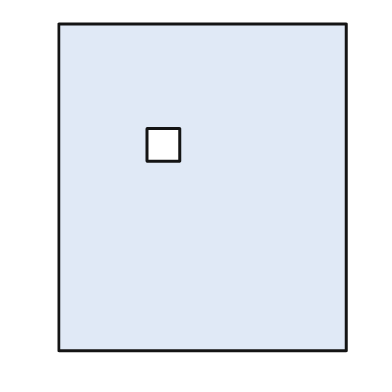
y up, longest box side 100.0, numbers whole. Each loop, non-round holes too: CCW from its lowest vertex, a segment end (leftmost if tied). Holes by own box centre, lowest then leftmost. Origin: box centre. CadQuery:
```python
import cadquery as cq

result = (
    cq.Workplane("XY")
    .moveTo(-44.0, -50.0)
    .lineTo(44.0, -50.0)
    .lineTo(44.0, 50.0)
    .lineTo(-44.0, 50.0)
    .close()
    .moveTo(-17.0, 8.0)
    .lineTo(-7.0, 8.0)
    .lineTo(-7.0, 18.0)
    .lineTo(-17.0, 18.0)
    .close()
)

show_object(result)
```